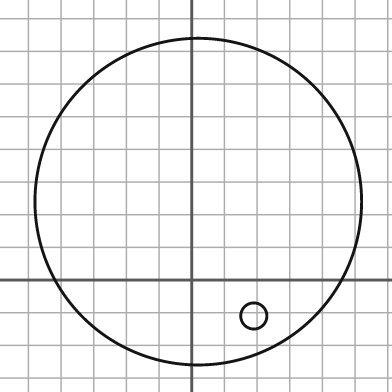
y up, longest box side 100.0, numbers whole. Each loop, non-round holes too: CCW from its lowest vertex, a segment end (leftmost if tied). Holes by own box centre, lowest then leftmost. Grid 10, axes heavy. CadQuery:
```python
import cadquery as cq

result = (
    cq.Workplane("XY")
    .moveTo(2.0, 24.0)
    .circle(50.0)
    .moveTo(19.0, -11.0)
    .circle(4.0)
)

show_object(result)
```